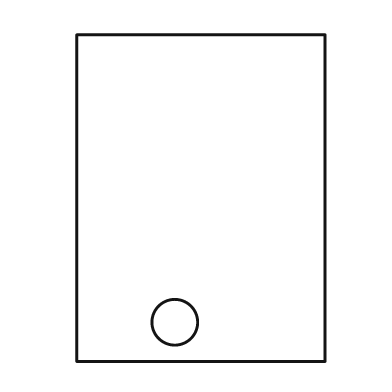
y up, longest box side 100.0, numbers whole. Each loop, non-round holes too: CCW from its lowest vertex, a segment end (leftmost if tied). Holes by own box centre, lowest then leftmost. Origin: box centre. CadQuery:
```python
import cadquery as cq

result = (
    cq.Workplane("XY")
    .moveTo(-38.0, -50.0)
    .lineTo(38.0, -50.0)
    .lineTo(38.0, 50.0)
    .lineTo(-38.0, 50.0)
    .close()
    .moveTo(-8.0, -38.0)
    .circle(7.0)
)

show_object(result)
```